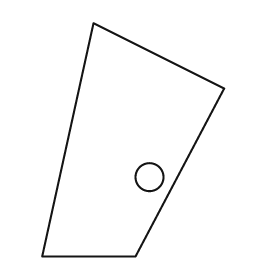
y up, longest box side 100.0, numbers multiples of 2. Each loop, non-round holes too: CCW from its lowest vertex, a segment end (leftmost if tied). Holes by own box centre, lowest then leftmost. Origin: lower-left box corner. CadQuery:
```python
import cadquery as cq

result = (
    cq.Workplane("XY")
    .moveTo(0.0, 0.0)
    .lineTo(40.0, 0.0)
    .lineTo(78.0, 72.0)
    .lineTo(22.0, 100.0)
    .close()
    .moveTo(46.0, 34.0)
    .circle(6.0)
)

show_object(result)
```